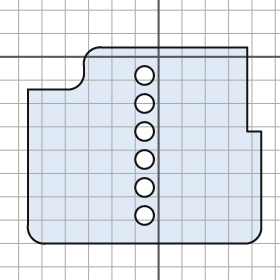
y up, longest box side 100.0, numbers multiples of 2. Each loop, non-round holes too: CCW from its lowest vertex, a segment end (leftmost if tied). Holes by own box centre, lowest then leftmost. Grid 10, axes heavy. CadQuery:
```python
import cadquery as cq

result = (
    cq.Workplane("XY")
    .moveTo(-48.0, -80.0)
    .lineTo(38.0, -80.0)
    .threePointArc((42.0, -78.0), (44.0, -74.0))
    .lineTo(44.0, -32.0)
    .lineTo(38.0, -32.0)
    .lineTo(38.0, 4.0)
    .lineTo(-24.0, 4.0)
    .threePointArc((-30.0, 2.0), (-32.0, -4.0))
    .lineTo(-32.0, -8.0)
    .threePointArc((-34.0, -12.0), (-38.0, -14.0))
    .lineTo(-56.0, -14.0)
    .lineTo(-56.0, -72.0)
    .threePointArc((-54.0, -78.0), (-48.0, -80.0))
    .close()
    .moveTo(-6.0, -68.0)
    .circle(4.0)
    .moveTo(-6.0, -56.0)
    .circle(4.0)
    .moveTo(-6.0, -44.0)
    .circle(4.0)
    .moveTo(-6.0, -32.0)
    .circle(4.0)
    .moveTo(-6.0, -20.0)
    .circle(4.0)
    .moveTo(-6.0, -8.0)
    .circle(4.0)
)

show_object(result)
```